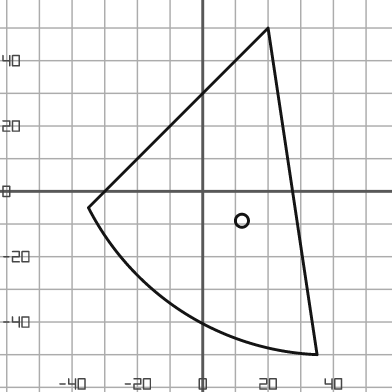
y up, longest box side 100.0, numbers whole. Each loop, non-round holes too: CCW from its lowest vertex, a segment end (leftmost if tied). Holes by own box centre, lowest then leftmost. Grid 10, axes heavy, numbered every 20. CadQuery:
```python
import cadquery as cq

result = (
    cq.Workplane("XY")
    .moveTo(35.0, -50.0)
    .lineTo(20.0, 50.0)
    .lineTo(-35.0, -5.0)
    .threePointArc((-6.0, -37.0), (35.0, -50.0))
    .close()
    .moveTo(12.0, -9.0)
    .circle(2.0)
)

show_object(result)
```